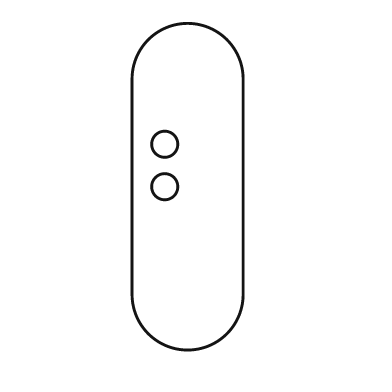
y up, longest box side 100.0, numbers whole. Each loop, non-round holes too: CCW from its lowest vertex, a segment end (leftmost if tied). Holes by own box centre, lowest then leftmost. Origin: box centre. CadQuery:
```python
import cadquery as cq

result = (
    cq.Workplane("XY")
    .moveTo(-17.0, -33.0)
    .threePointArc((0.0, -50.0), (17.0, -33.0))
    .lineTo(17.0, 33.0)
    .threePointArc((0.0, 50.0), (-17.0, 33.0))
    .close()
    .moveTo(-7.0, 0.0)
    .circle(4.0)
    .moveTo(-7.0, 13.0)
    .circle(4.0)
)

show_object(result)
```